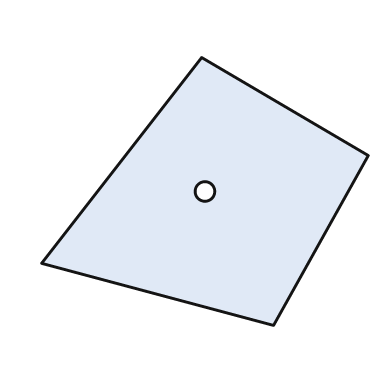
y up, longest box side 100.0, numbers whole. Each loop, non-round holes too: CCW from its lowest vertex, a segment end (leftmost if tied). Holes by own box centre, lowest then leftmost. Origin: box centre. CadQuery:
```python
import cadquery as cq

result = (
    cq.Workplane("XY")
    .moveTo(21.0, -41.0)
    .lineTo(50.0, 11.0)
    .lineTo(-1.0, 41.0)
    .lineTo(-50.0, -22.0)
    .close()
    .moveTo(0.0, 0.0)
    .circle(3.0)
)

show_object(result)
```